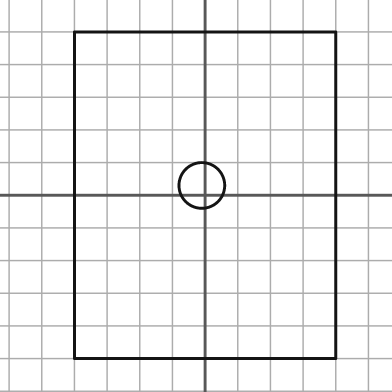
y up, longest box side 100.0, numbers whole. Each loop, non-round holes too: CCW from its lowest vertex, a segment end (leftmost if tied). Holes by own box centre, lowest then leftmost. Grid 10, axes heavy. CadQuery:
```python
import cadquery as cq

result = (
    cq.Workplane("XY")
    .moveTo(-40.0, -50.0)
    .lineTo(40.0, -50.0)
    .lineTo(40.0, 50.0)
    .lineTo(-40.0, 50.0)
    .close()
    .moveTo(-1.0, 3.0)
    .circle(7.0)
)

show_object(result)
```